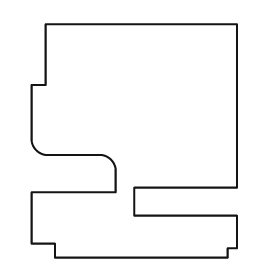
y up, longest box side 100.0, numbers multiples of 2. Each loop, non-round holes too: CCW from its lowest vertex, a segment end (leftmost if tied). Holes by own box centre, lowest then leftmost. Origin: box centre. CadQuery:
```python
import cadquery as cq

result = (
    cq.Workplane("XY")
    .moveTo(-34.0, -50.0)
    .lineTo(40.0, -50.0)
    .lineTo(40.0, -46.0)
    .lineTo(44.0, -46.0)
    .lineTo(44.0, -32.0)
    .lineTo(0.0, -32.0)
    .lineTo(0.0, -20.0)
    .lineTo(44.0, -20.0)
    .lineTo(44.0, 50.0)
    .lineTo(-38.0, 50.0)
    .lineTo(-38.0, 24.0)
    .lineTo(-44.0, 24.0)
    .lineTo(-44.0, 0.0)
    .threePointArc((-42.0, -4.0), (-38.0, -6.0))
    .lineTo(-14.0, -6.0)
    .threePointArc((-10.0, -8.0), (-8.0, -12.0))
    .lineTo(-8.0, -22.0)
    .lineTo(-44.0, -22.0)
    .lineTo(-44.0, -44.0)
    .lineTo(-34.0, -44.0)
    .close()
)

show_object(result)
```